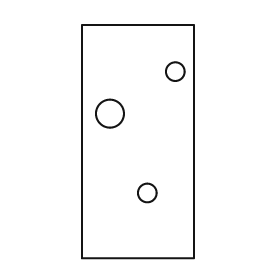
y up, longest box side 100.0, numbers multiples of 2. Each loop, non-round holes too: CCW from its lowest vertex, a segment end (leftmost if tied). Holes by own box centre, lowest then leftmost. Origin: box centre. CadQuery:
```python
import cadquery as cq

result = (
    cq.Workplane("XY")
    .moveTo(-24.0, -50.0)
    .lineTo(24.0, -50.0)
    .lineTo(24.0, 50.0)
    .lineTo(-24.0, 50.0)
    .close()
    .moveTo(4.0, -22.0)
    .circle(4.0)
    .moveTo(-12.0, 12.0)
    .circle(6.0)
    .moveTo(16.0, 30.0)
    .circle(4.0)
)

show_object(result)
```